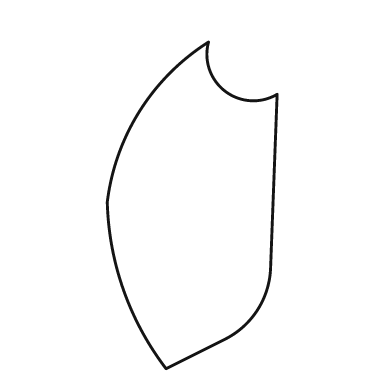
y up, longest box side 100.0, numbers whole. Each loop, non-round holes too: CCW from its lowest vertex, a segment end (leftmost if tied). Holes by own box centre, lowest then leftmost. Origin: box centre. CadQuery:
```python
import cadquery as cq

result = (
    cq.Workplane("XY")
    .moveTo(-8.0, -50.0)
    .lineTo(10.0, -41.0)
    .threePointArc((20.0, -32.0), (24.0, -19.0))
    .lineTo(26.0, 34.0)
    .threePointArc((10.0, 35.0), (5.0, 50.0))
    .threePointArc((-16.0, 29.0), (-26.0, 1.0))
    .threePointArc((-21.0, -26.0), (-8.0, -50.0))
    .close()
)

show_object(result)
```